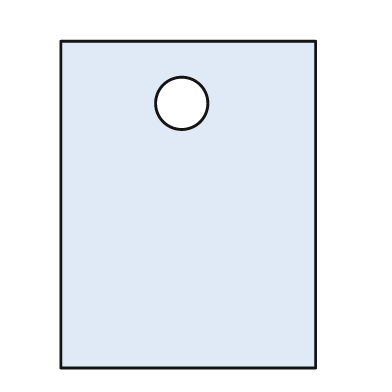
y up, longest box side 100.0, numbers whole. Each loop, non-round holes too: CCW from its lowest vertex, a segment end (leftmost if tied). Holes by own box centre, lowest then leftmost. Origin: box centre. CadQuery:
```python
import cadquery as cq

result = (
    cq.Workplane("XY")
    .moveTo(-39.0, -50.0)
    .lineTo(39.0, -50.0)
    .lineTo(39.0, 50.0)
    .lineTo(-39.0, 50.0)
    .close()
    .moveTo(-2.0, 31.0)
    .circle(8.0)
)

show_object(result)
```